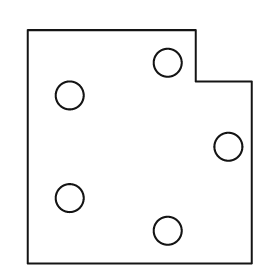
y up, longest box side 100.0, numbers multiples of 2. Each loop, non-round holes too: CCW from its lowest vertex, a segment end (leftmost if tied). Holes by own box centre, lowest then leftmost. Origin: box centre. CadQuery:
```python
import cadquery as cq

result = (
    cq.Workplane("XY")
    .moveTo(-48.0, -50.0)
    .lineTo(48.0, -50.0)
    .lineTo(48.0, 28.0)
    .lineTo(24.0, 28.0)
    .lineTo(24.0, 50.0)
    .lineTo(-48.0, 50.0)
    .close()
    .moveTo(12.0, -36.0)
    .circle(6.0)
    .moveTo(-30.0, -22.0)
    .circle(6.0)
    .moveTo(38.0, 0.0)
    .circle(6.0)
    .moveTo(-30.0, 22.0)
    .circle(6.0)
    .moveTo(12.0, 36.0)
    .circle(6.0)
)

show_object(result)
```